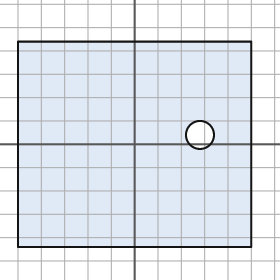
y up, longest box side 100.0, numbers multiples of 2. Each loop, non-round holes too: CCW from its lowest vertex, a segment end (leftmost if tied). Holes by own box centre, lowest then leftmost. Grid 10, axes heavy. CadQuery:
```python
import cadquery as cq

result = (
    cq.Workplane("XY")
    .moveTo(-50.0, -44.0)
    .lineTo(50.0, -44.0)
    .lineTo(50.0, 44.0)
    .lineTo(-50.0, 44.0)
    .close()
    .moveTo(28.0, 4.0)
    .circle(6.0)
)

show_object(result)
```